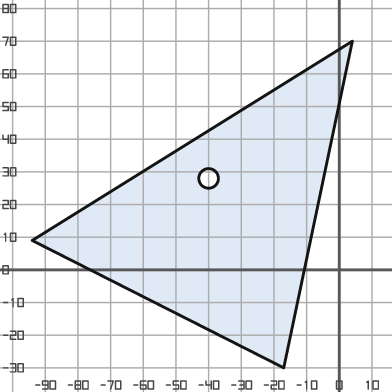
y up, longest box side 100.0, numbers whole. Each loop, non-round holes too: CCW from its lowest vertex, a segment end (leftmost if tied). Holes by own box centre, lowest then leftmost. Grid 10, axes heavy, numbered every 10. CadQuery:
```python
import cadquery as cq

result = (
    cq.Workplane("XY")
    .moveTo(-17.0, -30.0)
    .lineTo(4.0, 70.0)
    .lineTo(-94.0, 9.0)
    .close()
    .moveTo(-40.0, 28.0)
    .circle(3.0)
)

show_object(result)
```